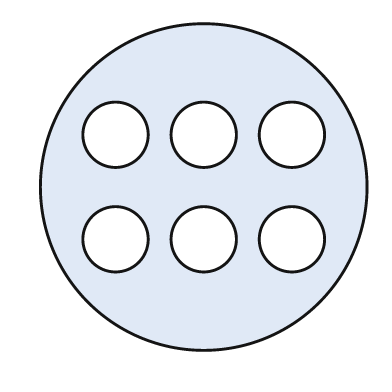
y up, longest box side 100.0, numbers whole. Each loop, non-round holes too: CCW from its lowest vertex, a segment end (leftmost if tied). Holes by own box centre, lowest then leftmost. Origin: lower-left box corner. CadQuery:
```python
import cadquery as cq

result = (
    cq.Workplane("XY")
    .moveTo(50.0, 50.0)
    .circle(50.0)
    .moveTo(23.0, 34.0)
    .circle(10.0)
    .moveTo(50.0, 34.0)
    .circle(10.0)
    .moveTo(77.0, 34.0)
    .circle(10.0)
    .moveTo(23.0, 66.0)
    .circle(10.0)
    .moveTo(50.0, 66.0)
    .circle(10.0)
    .moveTo(77.0, 66.0)
    .circle(10.0)
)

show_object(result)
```